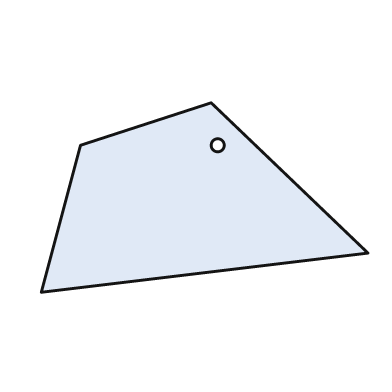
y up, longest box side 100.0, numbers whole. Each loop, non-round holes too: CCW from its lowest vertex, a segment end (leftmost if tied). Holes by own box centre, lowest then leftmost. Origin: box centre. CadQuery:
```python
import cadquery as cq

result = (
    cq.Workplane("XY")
    .moveTo(-50.0, -29.0)
    .lineTo(50.0, -17.0)
    .lineTo(2.0, 29.0)
    .lineTo(-38.0, 16.0)
    .close()
    .moveTo(4.0, 16.0)
    .circle(2.0)
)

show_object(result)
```